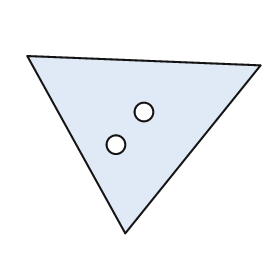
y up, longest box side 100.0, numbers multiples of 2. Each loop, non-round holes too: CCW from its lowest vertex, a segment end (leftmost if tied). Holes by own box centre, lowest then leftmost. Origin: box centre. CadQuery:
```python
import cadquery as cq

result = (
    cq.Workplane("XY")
    .moveTo(-8.0, -38.0)
    .lineTo(50.0, 34.0)
    .lineTo(-50.0, 38.0)
    .close()
    .moveTo(-12.0, 0.0)
    .circle(4.0)
    .moveTo(0.0, 14.0)
    .circle(4.0)
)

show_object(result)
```